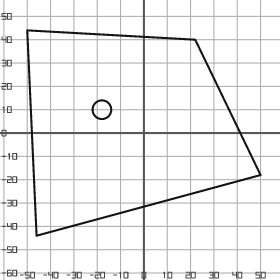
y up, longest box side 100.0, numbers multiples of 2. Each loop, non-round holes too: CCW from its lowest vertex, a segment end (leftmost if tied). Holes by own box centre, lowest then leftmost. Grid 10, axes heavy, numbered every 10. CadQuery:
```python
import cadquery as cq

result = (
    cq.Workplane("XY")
    .moveTo(-46.0, -44.0)
    .lineTo(50.0, -18.0)
    .lineTo(22.0, 40.0)
    .lineTo(-50.0, 44.0)
    .close()
    .moveTo(-18.0, 10.0)
    .circle(4.0)
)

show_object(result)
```